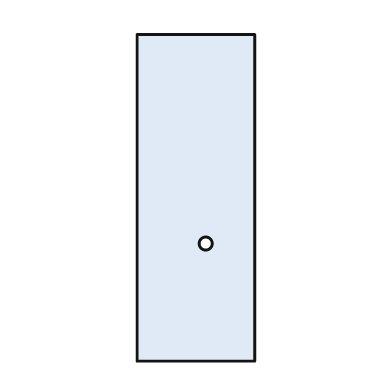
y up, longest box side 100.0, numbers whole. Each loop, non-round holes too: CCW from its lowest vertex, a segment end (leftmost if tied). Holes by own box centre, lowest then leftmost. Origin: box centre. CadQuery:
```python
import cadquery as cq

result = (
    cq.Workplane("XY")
    .moveTo(-18.0, -50.0)
    .lineTo(18.0, -50.0)
    .lineTo(18.0, 50.0)
    .lineTo(-18.0, 50.0)
    .close()
    .moveTo(3.0, -14.0)
    .circle(2.0)
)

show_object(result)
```